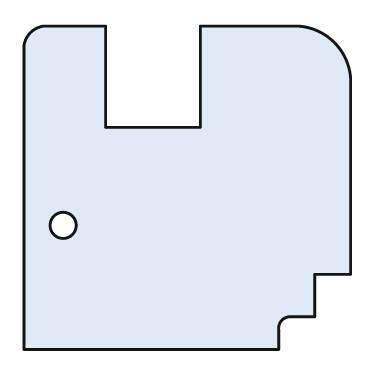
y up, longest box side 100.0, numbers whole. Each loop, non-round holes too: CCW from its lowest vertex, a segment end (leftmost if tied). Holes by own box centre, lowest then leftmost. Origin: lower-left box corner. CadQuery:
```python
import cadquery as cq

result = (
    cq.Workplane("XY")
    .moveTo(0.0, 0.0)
    .lineTo(78.0, 0.0)
    .lineTo(78.0, 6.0)
    .threePointArc((79.0, 9.0), (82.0, 10.0))
    .lineTo(89.0, 10.0)
    .lineTo(89.0, 23.0)
    .lineTo(100.0, 23.0)
    .lineTo(100.0, 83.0)
    .threePointArc((95.0, 94.0), (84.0, 99.0))
    .lineTo(54.0, 99.0)
    .lineTo(54.0, 68.0)
    .lineTo(25.0, 68.0)
    .lineTo(25.0, 99.0)
    .lineTo(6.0, 99.0)
    .threePointArc((2.0, 97.0), (0.0, 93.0))
    .close()
    .moveTo(12.0, 38.0)
    .circle(4.0)
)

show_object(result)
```